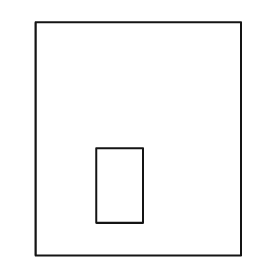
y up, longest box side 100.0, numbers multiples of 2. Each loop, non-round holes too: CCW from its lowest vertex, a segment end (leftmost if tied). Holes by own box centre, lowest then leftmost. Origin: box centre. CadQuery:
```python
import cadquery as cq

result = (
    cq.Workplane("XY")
    .moveTo(-44.0, -50.0)
    .lineTo(44.0, -50.0)
    .lineTo(44.0, 50.0)
    .lineTo(-44.0, 50.0)
    .close()
    .moveTo(-18.0, -36.0)
    .lineTo(2.0, -36.0)
    .lineTo(2.0, -4.0)
    .lineTo(-18.0, -4.0)
    .close()
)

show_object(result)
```